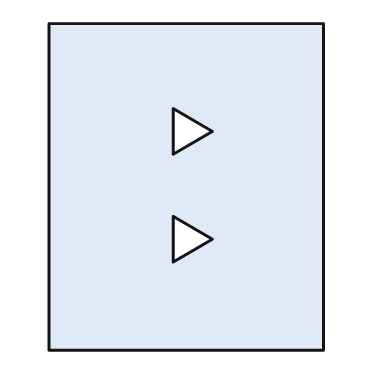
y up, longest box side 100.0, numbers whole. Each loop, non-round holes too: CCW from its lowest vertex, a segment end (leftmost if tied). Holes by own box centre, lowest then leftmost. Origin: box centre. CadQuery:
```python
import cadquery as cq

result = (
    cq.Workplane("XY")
    .moveTo(-42.0, -50.0)
    .lineTo(42.0, -50.0)
    .lineTo(42.0, 50.0)
    .lineTo(-42.0, 50.0)
    .close()
    .moveTo(-4.0, -23.0)
    .lineTo(8.0, -16.0)
    .lineTo(-4.0, -9.0)
    .close()
    .moveTo(-4.0, 10.0)
    .lineTo(8.0, 17.0)
    .lineTo(-4.0, 24.0)
    .close()
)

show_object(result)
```